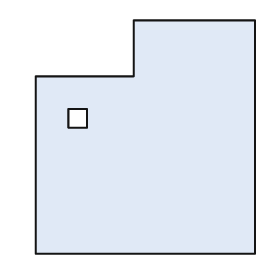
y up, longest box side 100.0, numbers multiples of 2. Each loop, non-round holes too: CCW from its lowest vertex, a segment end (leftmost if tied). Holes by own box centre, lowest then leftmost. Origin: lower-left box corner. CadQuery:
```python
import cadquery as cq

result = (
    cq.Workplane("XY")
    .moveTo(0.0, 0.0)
    .lineTo(94.0, 0.0)
    .lineTo(94.0, 100.0)
    .lineTo(42.0, 100.0)
    .lineTo(42.0, 76.0)
    .lineTo(0.0, 76.0)
    .close()
    .moveTo(14.0, 54.0)
    .lineTo(22.0, 54.0)
    .lineTo(22.0, 62.0)
    .lineTo(14.0, 62.0)
    .close()
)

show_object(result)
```